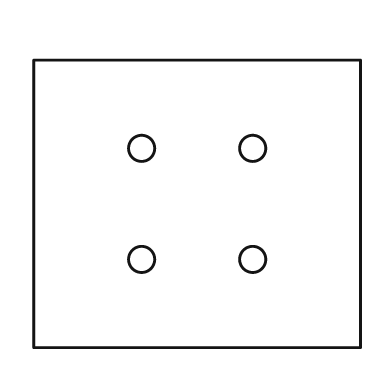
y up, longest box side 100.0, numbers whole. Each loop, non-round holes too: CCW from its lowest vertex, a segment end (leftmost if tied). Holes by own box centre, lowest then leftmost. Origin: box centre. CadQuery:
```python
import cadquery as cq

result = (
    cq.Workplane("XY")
    .moveTo(-50.0, -44.0)
    .lineTo(50.0, -44.0)
    .lineTo(50.0, 44.0)
    .lineTo(-50.0, 44.0)
    .close()
    .moveTo(-17.0, -17.0)
    .circle(4.0)
    .moveTo(17.0, -17.0)
    .circle(4.0)
    .moveTo(-17.0, 17.0)
    .circle(4.0)
    .moveTo(17.0, 17.0)
    .circle(4.0)
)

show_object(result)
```